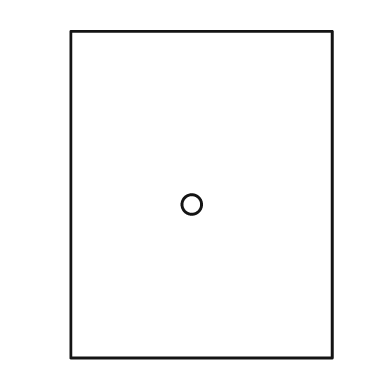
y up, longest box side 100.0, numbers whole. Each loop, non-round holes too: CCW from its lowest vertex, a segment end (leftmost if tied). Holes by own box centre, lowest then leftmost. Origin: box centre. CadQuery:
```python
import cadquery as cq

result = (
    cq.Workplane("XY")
    .moveTo(-40.0, -50.0)
    .lineTo(40.0, -50.0)
    .lineTo(40.0, 50.0)
    .lineTo(-40.0, 50.0)
    .close()
    .moveTo(-3.0, -3.0)
    .circle(3.0)
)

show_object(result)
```